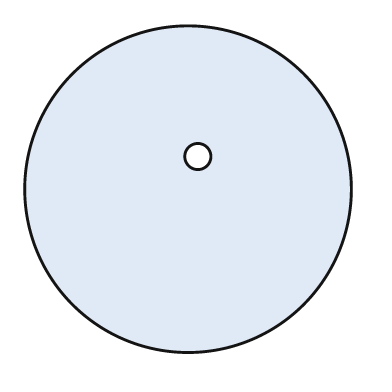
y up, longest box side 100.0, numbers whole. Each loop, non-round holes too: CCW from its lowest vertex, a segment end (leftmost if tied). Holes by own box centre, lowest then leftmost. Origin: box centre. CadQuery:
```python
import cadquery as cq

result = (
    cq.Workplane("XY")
    .moveTo(0.0, 0.0)
    .circle(50.0)
    .moveTo(3.0, 10.0)
    .circle(4.0)
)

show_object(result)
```